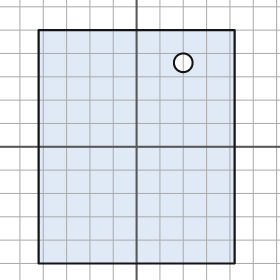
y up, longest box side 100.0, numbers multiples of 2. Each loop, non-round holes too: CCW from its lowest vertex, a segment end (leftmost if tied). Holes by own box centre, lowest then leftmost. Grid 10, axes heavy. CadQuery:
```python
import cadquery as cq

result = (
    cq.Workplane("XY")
    .moveTo(-42.0, -50.0)
    .lineTo(42.0, -50.0)
    .lineTo(42.0, 50.0)
    .lineTo(-42.0, 50.0)
    .close()
    .moveTo(20.0, 36.0)
    .circle(4.0)
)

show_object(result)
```